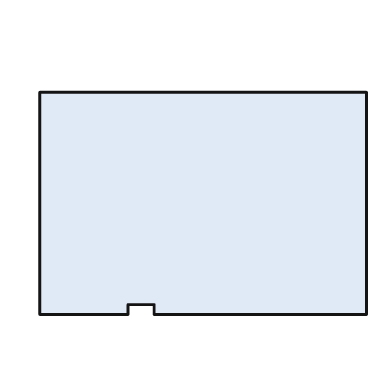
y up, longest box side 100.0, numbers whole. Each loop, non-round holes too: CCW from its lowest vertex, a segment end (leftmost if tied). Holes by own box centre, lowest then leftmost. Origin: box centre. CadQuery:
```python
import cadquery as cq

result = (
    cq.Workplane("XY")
    .moveTo(-50.0, -34.0)
    .lineTo(-23.0, -34.0)
    .lineTo(-23.0, -31.0)
    .lineTo(-15.0, -31.0)
    .lineTo(-15.0, -34.0)
    .lineTo(50.0, -34.0)
    .lineTo(50.0, 34.0)
    .lineTo(-50.0, 34.0)
    .close()
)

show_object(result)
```